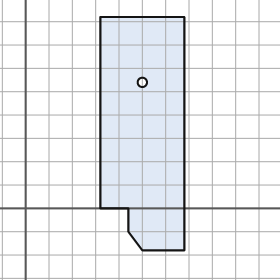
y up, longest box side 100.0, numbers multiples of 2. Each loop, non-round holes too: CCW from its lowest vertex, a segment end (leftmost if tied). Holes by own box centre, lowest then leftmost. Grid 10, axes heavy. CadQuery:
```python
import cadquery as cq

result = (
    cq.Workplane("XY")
    .moveTo(50.0, -18.0)
    .lineTo(68.0, -18.0)
    .lineTo(68.0, 82.0)
    .lineTo(32.0, 82.0)
    .lineTo(32.0, 0.0)
    .lineTo(44.0, 0.0)
    .lineTo(44.0, -10.0)
    .close()
    .moveTo(50.0, 54.0)
    .circle(2.0)
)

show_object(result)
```